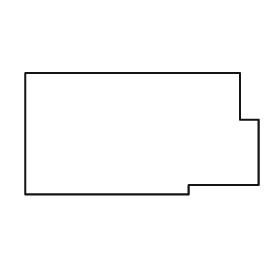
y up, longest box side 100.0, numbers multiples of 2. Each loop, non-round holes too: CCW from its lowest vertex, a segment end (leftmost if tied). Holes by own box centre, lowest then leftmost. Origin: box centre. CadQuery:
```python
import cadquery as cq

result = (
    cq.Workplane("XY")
    .moveTo(-50.0, -26.0)
    .lineTo(20.0, -26.0)
    .lineTo(20.0, -22.0)
    .lineTo(50.0, -22.0)
    .lineTo(50.0, 6.0)
    .lineTo(42.0, 6.0)
    .lineTo(42.0, 26.0)
    .lineTo(-50.0, 26.0)
    .close()
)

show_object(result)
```